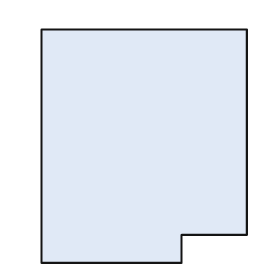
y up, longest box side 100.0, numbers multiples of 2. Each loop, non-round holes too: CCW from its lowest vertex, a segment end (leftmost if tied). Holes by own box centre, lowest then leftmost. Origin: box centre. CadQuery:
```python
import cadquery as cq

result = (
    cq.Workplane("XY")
    .moveTo(-44.0, -50.0)
    .lineTo(16.0, -50.0)
    .lineTo(16.0, -38.0)
    .lineTo(44.0, -38.0)
    .lineTo(44.0, 50.0)
    .lineTo(-44.0, 50.0)
    .close()
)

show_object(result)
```